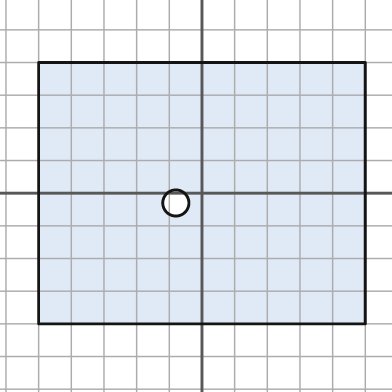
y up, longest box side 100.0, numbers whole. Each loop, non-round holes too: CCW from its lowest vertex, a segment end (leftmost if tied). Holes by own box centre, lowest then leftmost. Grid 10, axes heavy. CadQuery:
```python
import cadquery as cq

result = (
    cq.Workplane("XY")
    .moveTo(-50.0, -40.0)
    .lineTo(50.0, -40.0)
    .lineTo(50.0, 40.0)
    .lineTo(-50.0, 40.0)
    .close()
    .moveTo(-8.0, -3.0)
    .circle(4.0)
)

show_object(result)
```